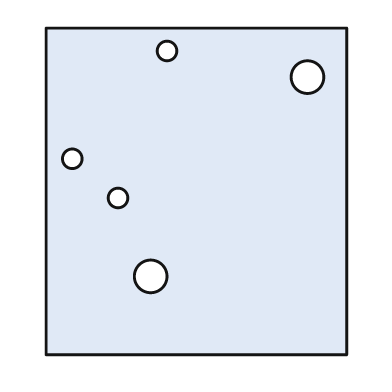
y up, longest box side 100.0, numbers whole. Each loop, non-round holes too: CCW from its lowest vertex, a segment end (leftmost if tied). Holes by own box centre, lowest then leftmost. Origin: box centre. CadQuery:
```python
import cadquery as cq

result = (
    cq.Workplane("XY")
    .moveTo(-46.0, -50.0)
    .lineTo(46.0, -50.0)
    .lineTo(46.0, 50.0)
    .lineTo(-46.0, 50.0)
    .close()
    .moveTo(-14.0, -26.0)
    .circle(5.0)
    .moveTo(-24.0, -2.0)
    .circle(3.0)
    .moveTo(-38.0, 10.0)
    .circle(3.0)
    .moveTo(34.0, 35.0)
    .circle(5.0)
    .moveTo(-9.0, 43.0)
    .circle(3.0)
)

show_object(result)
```